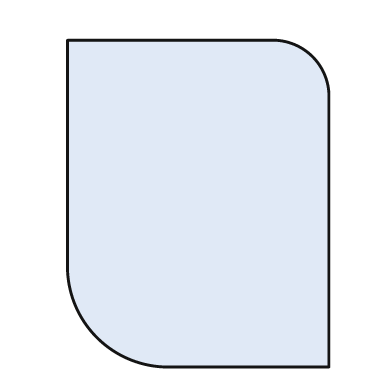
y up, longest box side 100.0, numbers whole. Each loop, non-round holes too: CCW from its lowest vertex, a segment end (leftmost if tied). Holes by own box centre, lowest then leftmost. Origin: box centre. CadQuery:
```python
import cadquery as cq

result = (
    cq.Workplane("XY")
    .moveTo(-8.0, -50.0)
    .lineTo(40.0, -50.0)
    .lineTo(40.0, 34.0)
    .threePointArc((35.0, 45.0), (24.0, 50.0))
    .lineTo(-40.0, 50.0)
    .lineTo(-40.0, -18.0)
    .threePointArc((-31.0, -41.0), (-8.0, -50.0))
    .close()
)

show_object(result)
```